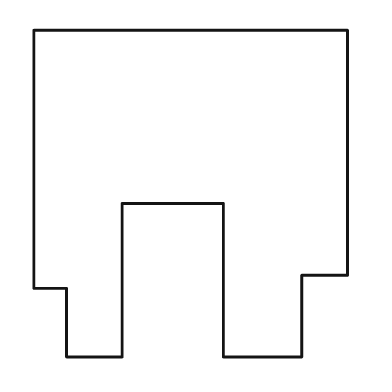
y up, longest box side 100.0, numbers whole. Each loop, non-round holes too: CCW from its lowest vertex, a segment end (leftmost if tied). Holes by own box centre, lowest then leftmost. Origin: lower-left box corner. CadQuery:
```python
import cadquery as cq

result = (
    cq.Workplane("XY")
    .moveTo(10.0, 0.0)
    .lineTo(27.0, 0.0)
    .lineTo(27.0, 47.0)
    .lineTo(58.0, 47.0)
    .lineTo(58.0, 0.0)
    .lineTo(82.0, 0.0)
    .lineTo(82.0, 25.0)
    .lineTo(96.0, 25.0)
    .lineTo(96.0, 100.0)
    .lineTo(0.0, 100.0)
    .lineTo(0.0, 21.0)
    .lineTo(10.0, 21.0)
    .close()
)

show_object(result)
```